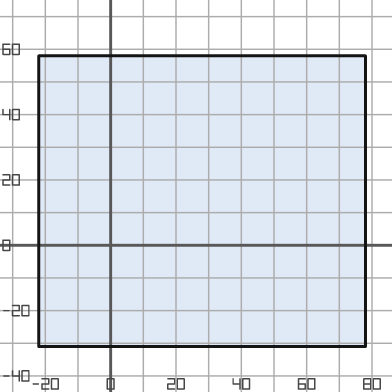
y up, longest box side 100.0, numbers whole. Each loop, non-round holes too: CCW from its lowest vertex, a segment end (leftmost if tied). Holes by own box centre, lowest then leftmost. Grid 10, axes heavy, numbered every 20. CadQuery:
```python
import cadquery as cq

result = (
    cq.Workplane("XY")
    .moveTo(-22.0, -31.0)
    .lineTo(78.0, -31.0)
    .lineTo(78.0, 58.0)
    .lineTo(-22.0, 58.0)
    .close()
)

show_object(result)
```